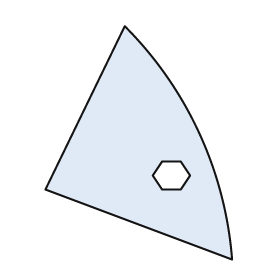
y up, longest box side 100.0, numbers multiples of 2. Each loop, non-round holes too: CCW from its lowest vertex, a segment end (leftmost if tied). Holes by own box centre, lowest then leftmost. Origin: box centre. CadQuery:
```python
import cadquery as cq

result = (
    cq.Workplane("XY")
    .moveTo(40.0, -50.0)
    .threePointArc((26.0, 4.0), (-6.0, 50.0))
    .lineTo(-40.0, -20.0)
    .close()
    .moveTo(10.0, -20.0)
    .lineTo(18.0, -20.0)
    .lineTo(22.0, -14.0)
    .lineTo(18.0, -8.0)
    .lineTo(10.0, -8.0)
    .lineTo(6.0, -14.0)
    .close()
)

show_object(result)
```